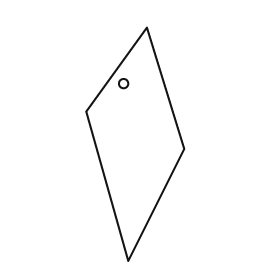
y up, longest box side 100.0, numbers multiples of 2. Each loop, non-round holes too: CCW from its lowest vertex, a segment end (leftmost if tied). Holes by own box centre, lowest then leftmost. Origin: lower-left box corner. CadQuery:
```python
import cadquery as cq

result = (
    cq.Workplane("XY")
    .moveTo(18.0, 0.0)
    .lineTo(42.0, 48.0)
    .lineTo(26.0, 100.0)
    .lineTo(0.0, 64.0)
    .close()
    .moveTo(16.0, 76.0)
    .circle(2.0)
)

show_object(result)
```